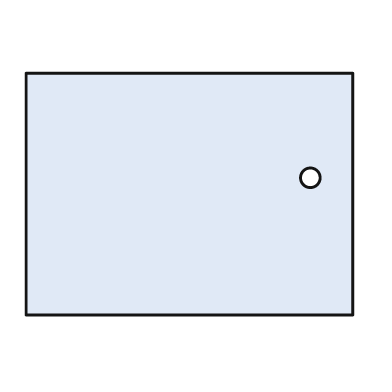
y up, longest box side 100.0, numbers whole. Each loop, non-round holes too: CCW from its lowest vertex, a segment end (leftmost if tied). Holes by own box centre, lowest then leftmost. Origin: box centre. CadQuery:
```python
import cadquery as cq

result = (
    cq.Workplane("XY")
    .moveTo(-50.0, -37.0)
    .lineTo(50.0, -37.0)
    .lineTo(50.0, 37.0)
    .lineTo(-50.0, 37.0)
    .close()
    .moveTo(37.0, 5.0)
    .circle(3.0)
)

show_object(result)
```